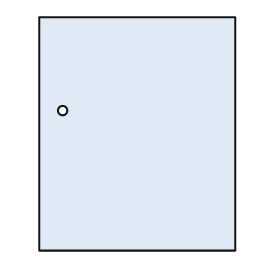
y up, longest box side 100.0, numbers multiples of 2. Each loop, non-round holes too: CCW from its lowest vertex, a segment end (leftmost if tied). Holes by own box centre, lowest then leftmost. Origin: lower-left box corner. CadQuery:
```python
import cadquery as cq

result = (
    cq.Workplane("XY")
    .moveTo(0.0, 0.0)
    .lineTo(84.0, 0.0)
    .lineTo(84.0, 100.0)
    .lineTo(0.0, 100.0)
    .close()
    .moveTo(10.0, 60.0)
    .circle(2.0)
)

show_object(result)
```